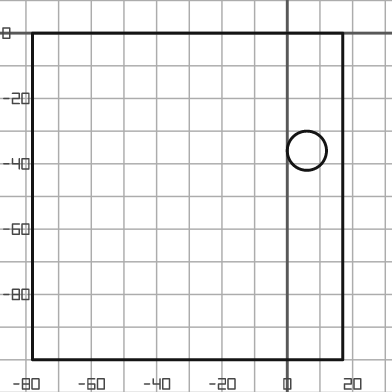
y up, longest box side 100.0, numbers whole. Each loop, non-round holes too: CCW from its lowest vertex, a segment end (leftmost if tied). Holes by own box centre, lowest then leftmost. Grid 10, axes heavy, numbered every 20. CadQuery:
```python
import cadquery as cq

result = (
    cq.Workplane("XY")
    .moveTo(-78.0, -100.0)
    .lineTo(17.0, -100.0)
    .lineTo(17.0, 0.0)
    .lineTo(-78.0, 0.0)
    .close()
    .moveTo(6.0, -36.0)
    .circle(6.0)
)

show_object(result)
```